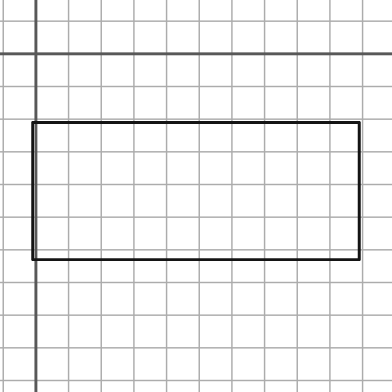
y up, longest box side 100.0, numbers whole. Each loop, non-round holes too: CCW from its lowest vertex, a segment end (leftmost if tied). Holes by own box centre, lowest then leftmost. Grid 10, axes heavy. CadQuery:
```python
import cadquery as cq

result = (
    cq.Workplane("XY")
    .moveTo(-1.0, -63.0)
    .lineTo(99.0, -63.0)
    .lineTo(99.0, -21.0)
    .lineTo(-1.0, -21.0)
    .close()
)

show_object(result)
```